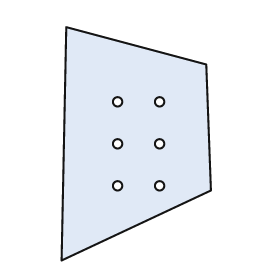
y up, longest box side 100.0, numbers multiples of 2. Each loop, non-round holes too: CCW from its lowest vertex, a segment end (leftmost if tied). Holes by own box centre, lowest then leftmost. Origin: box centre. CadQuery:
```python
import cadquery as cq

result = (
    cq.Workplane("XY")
    .moveTo(-32.0, -50.0)
    .lineTo(32.0, -20.0)
    .lineTo(30.0, 34.0)
    .lineTo(-30.0, 50.0)
    .close()
    .moveTo(-8.0, -18.0)
    .circle(2.0)
    .moveTo(10.0, -18.0)
    .circle(2.0)
    .moveTo(-8.0, 0.0)
    .circle(2.0)
    .moveTo(10.0, 0.0)
    .circle(2.0)
    .moveTo(-8.0, 18.0)
    .circle(2.0)
    .moveTo(10.0, 18.0)
    .circle(2.0)
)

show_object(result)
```